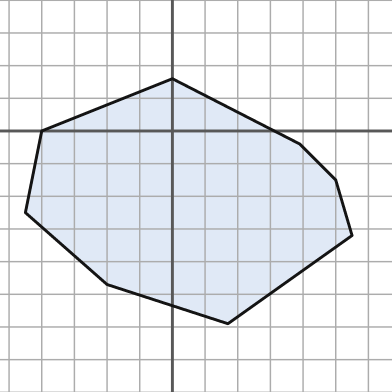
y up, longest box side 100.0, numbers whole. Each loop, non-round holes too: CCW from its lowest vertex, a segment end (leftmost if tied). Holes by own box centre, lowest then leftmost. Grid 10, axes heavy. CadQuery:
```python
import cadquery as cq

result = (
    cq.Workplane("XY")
    .moveTo(17.0, -59.0)
    .lineTo(55.0, -32.0)
    .lineTo(50.0, -15.0)
    .lineTo(39.0, -4.0)
    .lineTo(0.0, 16.0)
    .lineTo(-40.0, 0.0)
    .lineTo(-45.0, -25.0)
    .lineTo(-20.0, -47.0)
    .close()
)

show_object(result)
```